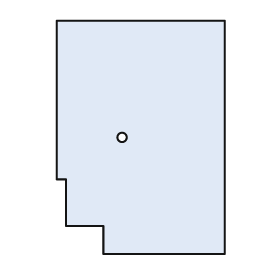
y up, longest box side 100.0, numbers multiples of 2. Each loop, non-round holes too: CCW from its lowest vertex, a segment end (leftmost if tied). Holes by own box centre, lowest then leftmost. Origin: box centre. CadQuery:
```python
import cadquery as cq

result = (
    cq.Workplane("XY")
    .moveTo(-16.0, -50.0)
    .lineTo(36.0, -50.0)
    .lineTo(36.0, 50.0)
    .lineTo(-36.0, 50.0)
    .lineTo(-36.0, -18.0)
    .lineTo(-32.0, -18.0)
    .lineTo(-32.0, -38.0)
    .lineTo(-16.0, -38.0)
    .close()
    .moveTo(-8.0, 0.0)
    .circle(2.0)
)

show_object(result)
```